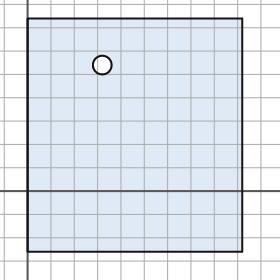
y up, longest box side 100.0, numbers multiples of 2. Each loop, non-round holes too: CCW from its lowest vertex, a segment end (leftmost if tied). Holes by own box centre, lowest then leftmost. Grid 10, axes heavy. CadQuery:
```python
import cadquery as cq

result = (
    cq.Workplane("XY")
    .moveTo(0.0, -26.0)
    .lineTo(92.0, -26.0)
    .lineTo(92.0, 74.0)
    .lineTo(0.0, 74.0)
    .close()
    .moveTo(32.0, 54.0)
    .circle(4.0)
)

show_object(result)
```